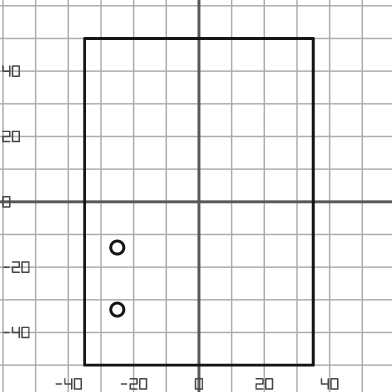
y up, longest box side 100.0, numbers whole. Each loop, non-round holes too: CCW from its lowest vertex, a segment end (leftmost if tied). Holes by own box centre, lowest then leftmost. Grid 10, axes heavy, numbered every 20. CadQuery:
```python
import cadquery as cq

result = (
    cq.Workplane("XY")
    .moveTo(-35.0, -50.0)
    .lineTo(35.0, -50.0)
    .lineTo(35.0, 50.0)
    .lineTo(-35.0, 50.0)
    .close()
    .moveTo(-25.0, -33.0)
    .circle(2.0)
    .moveTo(-25.0, -14.0)
    .circle(2.0)
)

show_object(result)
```